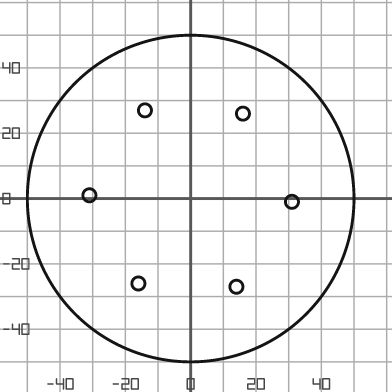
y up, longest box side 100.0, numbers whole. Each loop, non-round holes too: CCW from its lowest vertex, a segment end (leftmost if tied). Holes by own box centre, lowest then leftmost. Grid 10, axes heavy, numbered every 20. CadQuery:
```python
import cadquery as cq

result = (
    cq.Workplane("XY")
    .moveTo(0.0, 0.0)
    .circle(50.0)
    .moveTo(14.0, -27.0)
    .circle(2.0)
    .moveTo(-16.0, -26.0)
    .circle(2.0)
    .moveTo(31.0, -1.0)
    .circle(2.0)
    .moveTo(-31.0, 1.0)
    .circle(2.0)
    .moveTo(16.0, 26.0)
    .circle(2.0)
    .moveTo(-14.0, 27.0)
    .circle(2.0)
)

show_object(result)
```